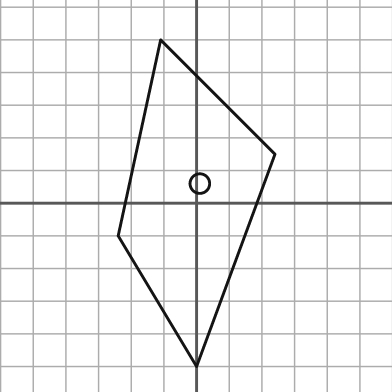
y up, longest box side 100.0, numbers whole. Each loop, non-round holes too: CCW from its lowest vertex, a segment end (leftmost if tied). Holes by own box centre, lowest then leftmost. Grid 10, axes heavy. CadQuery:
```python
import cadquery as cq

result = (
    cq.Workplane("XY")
    .moveTo(0.0, -50.0)
    .lineTo(24.0, 15.0)
    .lineTo(-11.0, 50.0)
    .lineTo(-24.0, -10.0)
    .close()
    .moveTo(1.0, 6.0)
    .circle(3.0)
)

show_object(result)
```